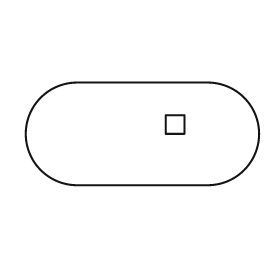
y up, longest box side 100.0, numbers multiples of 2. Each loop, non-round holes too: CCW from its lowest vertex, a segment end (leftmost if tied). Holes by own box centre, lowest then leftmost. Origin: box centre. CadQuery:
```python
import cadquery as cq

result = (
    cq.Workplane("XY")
    .moveTo(-28.0, -22.0)
    .lineTo(28.0, -22.0)
    .threePointArc((50.0, 0.0), (28.0, 22.0))
    .lineTo(-28.0, 22.0)
    .threePointArc((-50.0, 0.0), (-28.0, -22.0))
    .close()
    .moveTo(10.0, 0.0)
    .lineTo(18.0, 0.0)
    .lineTo(18.0, 8.0)
    .lineTo(10.0, 8.0)
    .close()
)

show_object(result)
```